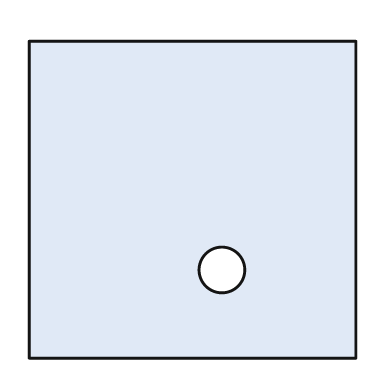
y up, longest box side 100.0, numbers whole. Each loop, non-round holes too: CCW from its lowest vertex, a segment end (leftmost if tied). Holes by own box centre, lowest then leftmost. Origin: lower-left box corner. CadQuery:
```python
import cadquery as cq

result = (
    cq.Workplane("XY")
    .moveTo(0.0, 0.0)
    .lineTo(100.0, 0.0)
    .lineTo(100.0, 97.0)
    .lineTo(0.0, 97.0)
    .close()
    .moveTo(59.0, 27.0)
    .circle(7.0)
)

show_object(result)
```